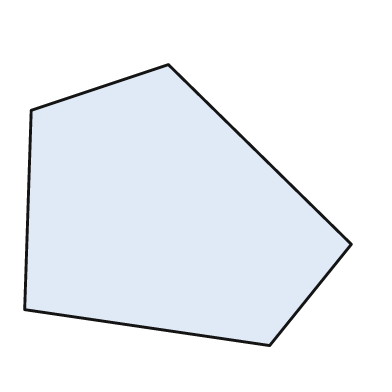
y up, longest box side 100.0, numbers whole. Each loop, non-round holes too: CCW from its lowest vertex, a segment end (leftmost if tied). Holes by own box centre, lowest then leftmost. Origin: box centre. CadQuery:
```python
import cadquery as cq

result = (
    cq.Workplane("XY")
    .moveTo(25.0, -43.0)
    .lineTo(50.0, -12.0)
    .lineTo(-6.0, 43.0)
    .lineTo(-48.0, 29.0)
    .lineTo(-50.0, -32.0)
    .close()
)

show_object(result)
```